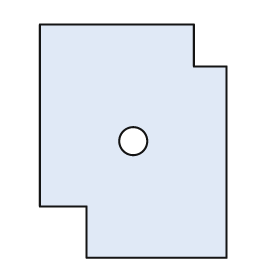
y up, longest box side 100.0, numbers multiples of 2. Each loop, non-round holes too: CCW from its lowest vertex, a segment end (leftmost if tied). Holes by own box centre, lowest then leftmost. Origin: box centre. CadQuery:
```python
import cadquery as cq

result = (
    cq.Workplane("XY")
    .moveTo(-20.0, -50.0)
    .lineTo(40.0, -50.0)
    .lineTo(40.0, 32.0)
    .lineTo(26.0, 32.0)
    .lineTo(26.0, 50.0)
    .lineTo(-40.0, 50.0)
    .lineTo(-40.0, -28.0)
    .lineTo(-20.0, -28.0)
    .close()
    .moveTo(0.0, 0.0)
    .circle(6.0)
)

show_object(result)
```